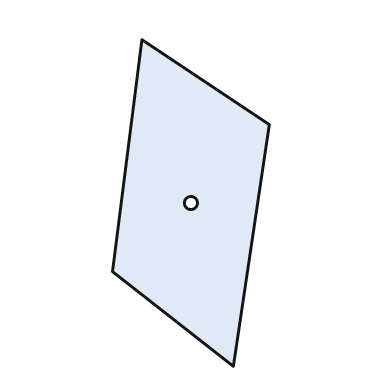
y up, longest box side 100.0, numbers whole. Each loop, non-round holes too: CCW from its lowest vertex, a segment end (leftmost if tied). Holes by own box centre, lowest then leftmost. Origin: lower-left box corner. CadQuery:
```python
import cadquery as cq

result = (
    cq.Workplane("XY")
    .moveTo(37.0, 0.0)
    .lineTo(48.0, 74.0)
    .lineTo(9.0, 100.0)
    .lineTo(0.0, 29.0)
    .close()
    .moveTo(24.0, 50.0)
    .circle(2.0)
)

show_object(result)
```